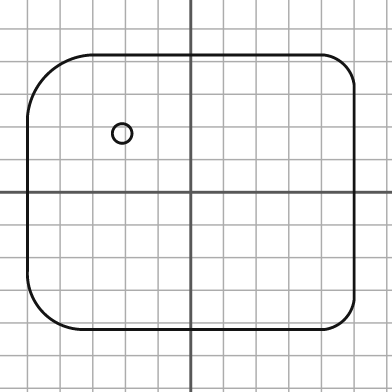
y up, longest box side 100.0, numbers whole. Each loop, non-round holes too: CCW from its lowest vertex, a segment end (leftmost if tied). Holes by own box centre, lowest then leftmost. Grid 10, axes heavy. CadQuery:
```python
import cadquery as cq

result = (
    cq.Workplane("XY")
    .moveTo(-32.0, -42.0)
    .lineTo(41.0, -42.0)
    .threePointArc((47.0, -39.0), (50.0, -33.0))
    .lineTo(50.0, 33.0)
    .threePointArc((47.0, 39.0), (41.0, 42.0))
    .lineTo(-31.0, 42.0)
    .threePointArc((-44.0, 36.0), (-50.0, 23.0))
    .lineTo(-50.0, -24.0)
    .threePointArc((-45.0, -37.0), (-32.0, -42.0))
    .close()
    .moveTo(-21.0, 18.0)
    .circle(3.0)
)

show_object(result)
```